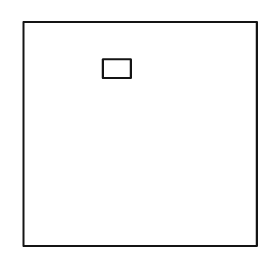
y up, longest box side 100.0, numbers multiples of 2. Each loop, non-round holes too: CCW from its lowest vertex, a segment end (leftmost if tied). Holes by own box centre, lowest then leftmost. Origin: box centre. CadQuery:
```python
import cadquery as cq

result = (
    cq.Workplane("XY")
    .moveTo(-50.0, -48.0)
    .lineTo(50.0, -48.0)
    .lineTo(50.0, 48.0)
    .lineTo(-50.0, 48.0)
    .close()
    .moveTo(-16.0, 24.0)
    .lineTo(-4.0, 24.0)
    .lineTo(-4.0, 32.0)
    .lineTo(-16.0, 32.0)
    .close()
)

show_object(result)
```